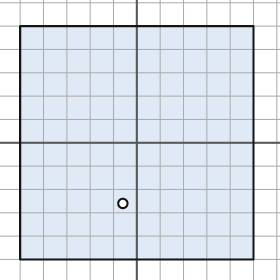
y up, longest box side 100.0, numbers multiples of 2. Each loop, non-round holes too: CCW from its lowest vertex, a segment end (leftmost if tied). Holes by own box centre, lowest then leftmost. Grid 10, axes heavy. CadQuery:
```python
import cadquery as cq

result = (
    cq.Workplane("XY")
    .moveTo(-50.0, -50.0)
    .lineTo(50.0, -50.0)
    .lineTo(50.0, 50.0)
    .lineTo(-50.0, 50.0)
    .close()
    .moveTo(-6.0, -26.0)
    .circle(2.0)
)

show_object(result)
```